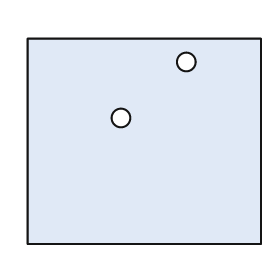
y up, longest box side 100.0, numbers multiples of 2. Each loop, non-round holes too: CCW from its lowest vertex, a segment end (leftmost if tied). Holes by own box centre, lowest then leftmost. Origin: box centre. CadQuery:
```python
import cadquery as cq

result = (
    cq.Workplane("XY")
    .moveTo(-50.0, -44.0)
    .lineTo(50.0, -44.0)
    .lineTo(50.0, 44.0)
    .lineTo(-50.0, 44.0)
    .close()
    .moveTo(-10.0, 10.0)
    .circle(4.0)
    .moveTo(18.0, 34.0)
    .circle(4.0)
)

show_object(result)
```